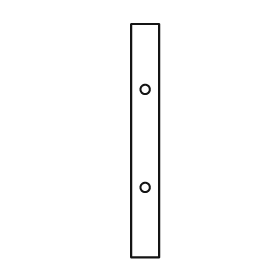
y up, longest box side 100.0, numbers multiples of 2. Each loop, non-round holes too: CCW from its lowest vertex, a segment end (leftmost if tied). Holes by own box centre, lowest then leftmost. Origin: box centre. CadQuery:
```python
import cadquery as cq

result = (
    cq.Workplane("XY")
    .moveTo(-6.0, -50.0)
    .lineTo(6.0, -50.0)
    .lineTo(6.0, 50.0)
    .lineTo(-6.0, 50.0)
    .close()
    .moveTo(0.0, -20.0)
    .circle(2.0)
    .moveTo(0.0, 22.0)
    .circle(2.0)
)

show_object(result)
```